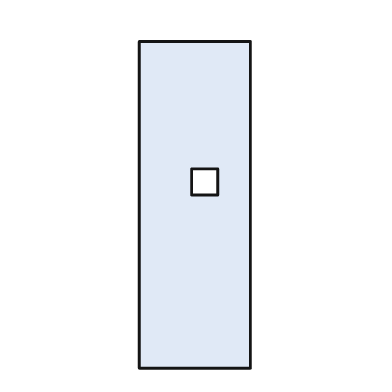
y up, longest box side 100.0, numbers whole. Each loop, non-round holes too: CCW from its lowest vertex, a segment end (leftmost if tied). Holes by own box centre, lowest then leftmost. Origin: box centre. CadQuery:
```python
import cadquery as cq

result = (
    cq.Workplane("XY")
    .moveTo(-17.0, -50.0)
    .lineTo(17.0, -50.0)
    .lineTo(17.0, 50.0)
    .lineTo(-17.0, 50.0)
    .close()
    .moveTo(-1.0, 3.0)
    .lineTo(7.0, 3.0)
    .lineTo(7.0, 11.0)
    .lineTo(-1.0, 11.0)
    .close()
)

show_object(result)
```